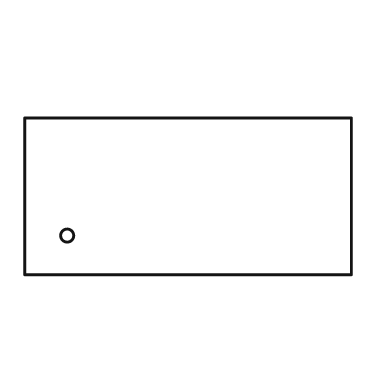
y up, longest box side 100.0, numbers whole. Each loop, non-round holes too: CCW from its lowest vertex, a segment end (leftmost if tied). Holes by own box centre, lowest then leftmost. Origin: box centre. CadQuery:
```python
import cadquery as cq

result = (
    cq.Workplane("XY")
    .moveTo(-50.0, -24.0)
    .lineTo(50.0, -24.0)
    .lineTo(50.0, 24.0)
    .lineTo(-50.0, 24.0)
    .close()
    .moveTo(-37.0, -12.0)
    .circle(2.0)
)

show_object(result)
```